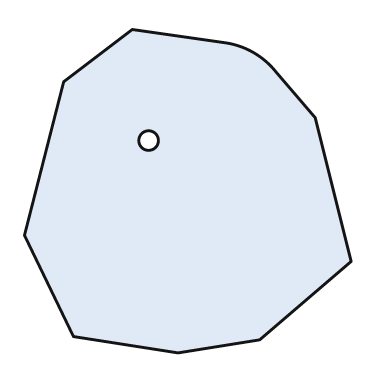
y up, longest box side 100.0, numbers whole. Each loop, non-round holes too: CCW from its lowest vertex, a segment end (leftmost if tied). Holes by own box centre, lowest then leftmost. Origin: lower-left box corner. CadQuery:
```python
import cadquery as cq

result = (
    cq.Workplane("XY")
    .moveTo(47.0, 0.0)
    .lineTo(72.0, 4.0)
    .lineTo(100.0, 28.0)
    .lineTo(89.0, 72.0)
    .lineTo(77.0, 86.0)
    .threePointArc((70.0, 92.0), (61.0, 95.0))
    .lineTo(33.0, 99.0)
    .lineTo(12.0, 83.0)
    .lineTo(0.0, 36.0)
    .lineTo(15.0, 5.0)
    .close()
    .moveTo(38.0, 65.0)
    .circle(3.0)
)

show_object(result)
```